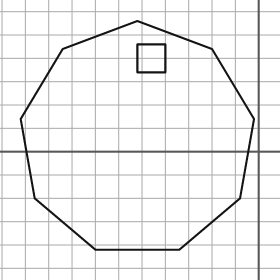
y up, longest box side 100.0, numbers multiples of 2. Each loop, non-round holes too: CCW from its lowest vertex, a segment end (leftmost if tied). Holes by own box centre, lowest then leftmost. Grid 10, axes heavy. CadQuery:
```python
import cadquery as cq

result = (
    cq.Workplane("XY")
    .moveTo(-70.0, -42.0)
    .lineTo(-34.0, -42.0)
    .lineTo(-8.0, -20.0)
    .lineTo(-2.0, 14.0)
    .lineTo(-20.0, 44.0)
    .lineTo(-52.0, 56.0)
    .lineTo(-84.0, 44.0)
    .lineTo(-102.0, 14.0)
    .lineTo(-96.0, -20.0)
    .close()
    .moveTo(-52.0, 34.0)
    .lineTo(-40.0, 34.0)
    .lineTo(-40.0, 46.0)
    .lineTo(-52.0, 46.0)
    .close()
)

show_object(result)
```